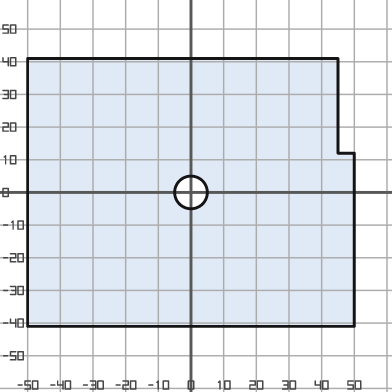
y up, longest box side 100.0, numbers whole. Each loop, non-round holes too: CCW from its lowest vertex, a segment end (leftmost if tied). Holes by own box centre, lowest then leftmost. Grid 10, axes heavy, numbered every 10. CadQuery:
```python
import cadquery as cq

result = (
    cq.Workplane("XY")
    .moveTo(-50.0, -41.0)
    .lineTo(50.0, -41.0)
    .lineTo(50.0, 12.0)
    .lineTo(45.0, 12.0)
    .lineTo(45.0, 41.0)
    .lineTo(-50.0, 41.0)
    .close()
    .moveTo(0.0, 0.0)
    .circle(5.0)
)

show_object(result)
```